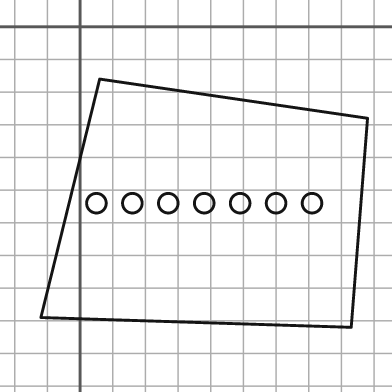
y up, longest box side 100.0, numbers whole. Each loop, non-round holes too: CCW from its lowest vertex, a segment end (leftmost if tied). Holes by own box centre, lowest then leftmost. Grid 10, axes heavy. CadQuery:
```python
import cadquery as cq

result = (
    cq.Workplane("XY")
    .moveTo(83.0, -92.0)
    .lineTo(88.0, -28.0)
    .lineTo(6.0, -16.0)
    .lineTo(-12.0, -89.0)
    .close()
    .moveTo(5.0, -54.0)
    .circle(3.0)
    .moveTo(16.0, -54.0)
    .circle(3.0)
    .moveTo(27.0, -54.0)
    .circle(3.0)
    .moveTo(38.0, -54.0)
    .circle(3.0)
    .moveTo(49.0, -54.0)
    .circle(3.0)
    .moveTo(60.0, -54.0)
    .circle(3.0)
    .moveTo(71.0, -54.0)
    .circle(3.0)
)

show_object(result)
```